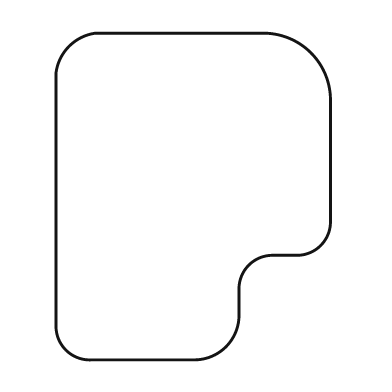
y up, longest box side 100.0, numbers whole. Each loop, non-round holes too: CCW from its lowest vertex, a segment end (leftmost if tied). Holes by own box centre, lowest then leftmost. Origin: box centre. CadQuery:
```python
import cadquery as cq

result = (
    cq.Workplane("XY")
    .moveTo(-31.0, -50.0)
    .lineTo(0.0, -50.0)
    .threePointArc((10.0, -46.0), (14.0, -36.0))
    .lineTo(14.0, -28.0)
    .threePointArc((17.0, -21.0), (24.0, -18.0))
    .lineTo(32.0, -18.0)
    .threePointArc((39.0, -15.0), (42.0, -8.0))
    .lineTo(42.0, 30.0)
    .threePointArc((36.0, 44.0), (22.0, 50.0))
    .lineTo(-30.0, 50.0)
    .threePointArc((-38.0, 46.0), (-42.0, 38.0))
    .lineTo(-42.0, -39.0)
    .threePointArc((-39.0, -47.0), (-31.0, -50.0))
    .close()
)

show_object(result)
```